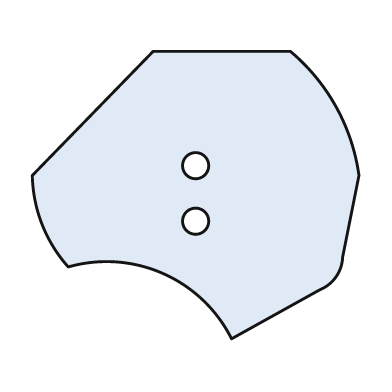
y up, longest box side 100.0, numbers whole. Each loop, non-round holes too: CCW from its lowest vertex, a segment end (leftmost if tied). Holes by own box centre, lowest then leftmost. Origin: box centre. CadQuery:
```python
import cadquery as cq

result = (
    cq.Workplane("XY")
    .moveTo(11.0, -44.0)
    .lineTo(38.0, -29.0)
    .threePointArc((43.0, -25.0), (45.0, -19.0))
    .lineTo(50.0, 6.0)
    .threePointArc((43.0, 27.0), (29.0, 44.0))
    .lineTo(-13.0, 44.0)
    .lineTo(-50.0, 6.0)
    .threePointArc((-47.0, -9.0), (-39.0, -22.0))
    .threePointArc((-10.0, -24.0), (11.0, -44.0))
    .close()
    .moveTo(0.0, -8.0)
    .circle(4.0)
    .moveTo(0.0, 9.0)
    .circle(4.0)
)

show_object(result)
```